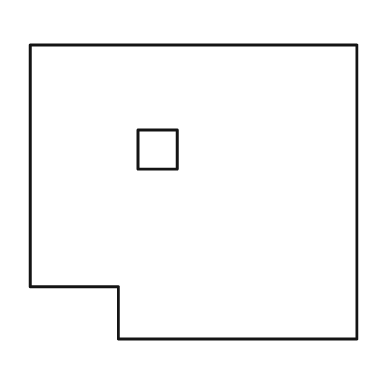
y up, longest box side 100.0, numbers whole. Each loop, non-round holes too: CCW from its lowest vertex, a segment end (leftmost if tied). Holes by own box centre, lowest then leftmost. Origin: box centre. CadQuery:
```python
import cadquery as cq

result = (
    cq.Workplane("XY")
    .moveTo(-23.0, -45.0)
    .lineTo(50.0, -45.0)
    .lineTo(50.0, 45.0)
    .lineTo(-50.0, 45.0)
    .lineTo(-50.0, -29.0)
    .lineTo(-23.0, -29.0)
    .close()
    .moveTo(-17.0, 7.0)
    .lineTo(-5.0, 7.0)
    .lineTo(-5.0, 19.0)
    .lineTo(-17.0, 19.0)
    .close()
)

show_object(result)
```